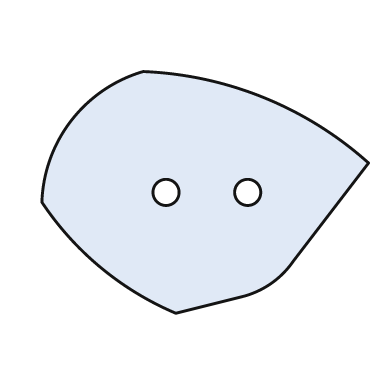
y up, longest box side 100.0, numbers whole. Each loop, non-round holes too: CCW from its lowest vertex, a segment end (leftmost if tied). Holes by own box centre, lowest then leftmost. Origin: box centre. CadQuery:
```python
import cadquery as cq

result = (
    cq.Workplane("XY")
    .moveTo(-9.0, -37.0)
    .lineTo(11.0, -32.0)
    .threePointArc((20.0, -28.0), (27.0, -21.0))
    .lineTo(50.0, 9.0)
    .threePointArc((18.0, 29.0), (-19.0, 37.0))
    .threePointArc((-41.0, 22.0), (-50.0, -3.0))
    .threePointArc((-32.0, -23.0), (-9.0, -37.0))
    .close()
    .moveTo(-12.0, 0.0)
    .circle(4.0)
    .moveTo(13.0, 0.0)
    .circle(4.0)
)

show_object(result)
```